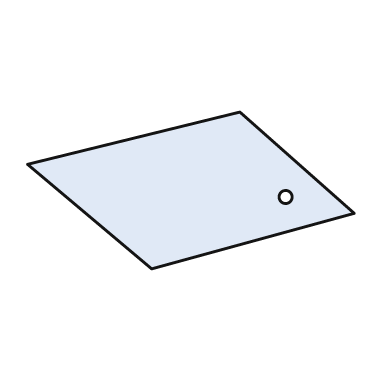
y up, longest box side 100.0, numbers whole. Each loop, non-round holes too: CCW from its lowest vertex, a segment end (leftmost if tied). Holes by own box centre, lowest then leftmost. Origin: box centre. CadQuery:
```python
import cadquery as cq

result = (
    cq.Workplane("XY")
    .moveTo(-12.0, -24.0)
    .lineTo(50.0, -7.0)
    .lineTo(15.0, 24.0)
    .lineTo(-50.0, 8.0)
    .close()
    .moveTo(29.0, -2.0)
    .circle(2.0)
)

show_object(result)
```